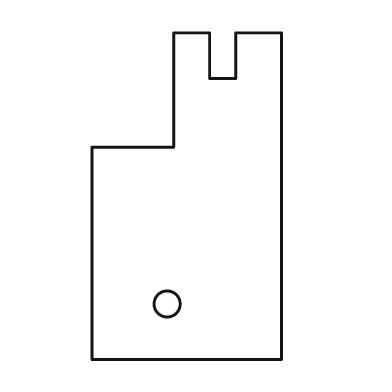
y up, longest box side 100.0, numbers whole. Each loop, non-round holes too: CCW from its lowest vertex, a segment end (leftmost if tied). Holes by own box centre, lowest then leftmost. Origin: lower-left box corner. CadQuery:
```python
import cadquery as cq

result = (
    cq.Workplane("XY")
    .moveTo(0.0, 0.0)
    .lineTo(58.0, 0.0)
    .lineTo(58.0, 100.0)
    .lineTo(44.0, 100.0)
    .lineTo(44.0, 86.0)
    .lineTo(36.0, 86.0)
    .lineTo(36.0, 100.0)
    .lineTo(25.0, 100.0)
    .lineTo(25.0, 65.0)
    .lineTo(0.0, 65.0)
    .close()
    .moveTo(23.0, 17.0)
    .circle(4.0)
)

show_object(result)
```